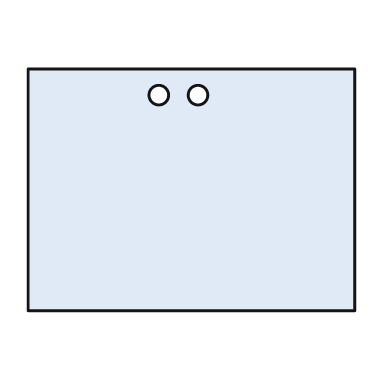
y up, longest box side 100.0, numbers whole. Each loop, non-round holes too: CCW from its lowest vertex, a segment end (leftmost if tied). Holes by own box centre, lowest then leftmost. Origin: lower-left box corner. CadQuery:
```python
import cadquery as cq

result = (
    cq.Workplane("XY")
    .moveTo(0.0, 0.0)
    .lineTo(100.0, 0.0)
    .lineTo(100.0, 74.0)
    .lineTo(0.0, 74.0)
    .close()
    .moveTo(40.0, 66.0)
    .circle(3.0)
    .moveTo(52.0, 66.0)
    .circle(3.0)
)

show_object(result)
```